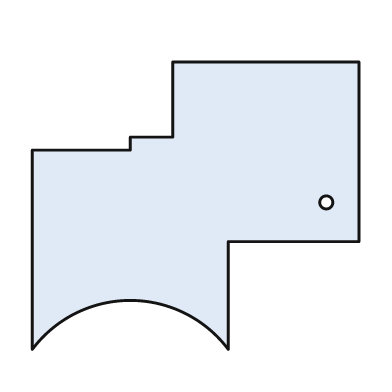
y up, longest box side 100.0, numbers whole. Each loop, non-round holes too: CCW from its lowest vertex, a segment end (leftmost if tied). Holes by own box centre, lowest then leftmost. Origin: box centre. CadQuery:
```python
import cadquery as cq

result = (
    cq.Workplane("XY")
    .moveTo(-50.0, -44.0)
    .threePointArc((-20.0, -29.0), (10.0, -44.0))
    .lineTo(10.0, -11.0)
    .lineTo(50.0, -11.0)
    .lineTo(50.0, 44.0)
    .lineTo(-7.0, 44.0)
    .lineTo(-7.0, 21.0)
    .lineTo(-20.0, 21.0)
    .lineTo(-20.0, 17.0)
    .lineTo(-50.0, 17.0)
    .close()
    .moveTo(40.0, 1.0)
    .circle(2.0)
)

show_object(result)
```